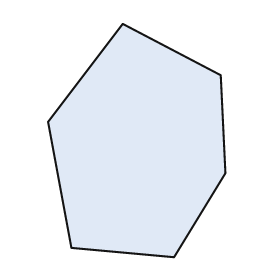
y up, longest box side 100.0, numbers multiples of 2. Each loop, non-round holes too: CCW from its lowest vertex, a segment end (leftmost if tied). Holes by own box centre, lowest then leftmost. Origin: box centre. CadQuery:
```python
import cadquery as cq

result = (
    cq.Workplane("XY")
    .moveTo(16.0, -50.0)
    .lineTo(38.0, -14.0)
    .lineTo(36.0, 28.0)
    .lineTo(-6.0, 50.0)
    .lineTo(-38.0, 8.0)
    .lineTo(-28.0, -46.0)
    .close()
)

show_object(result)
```